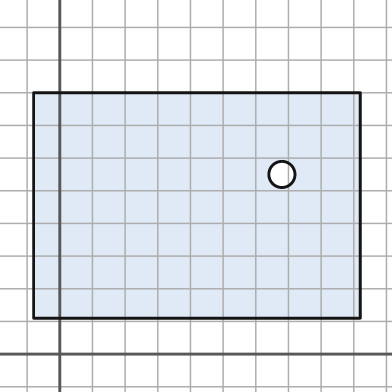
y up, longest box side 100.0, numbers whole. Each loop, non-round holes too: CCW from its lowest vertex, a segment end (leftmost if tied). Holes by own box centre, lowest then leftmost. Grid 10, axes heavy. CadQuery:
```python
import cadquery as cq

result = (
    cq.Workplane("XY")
    .moveTo(-8.0, 11.0)
    .lineTo(92.0, 11.0)
    .lineTo(92.0, 80.0)
    .lineTo(-8.0, 80.0)
    .close()
    .moveTo(68.0, 55.0)
    .circle(4.0)
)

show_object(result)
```